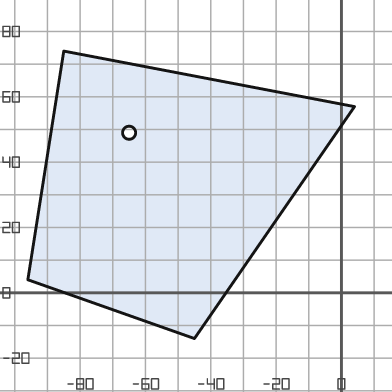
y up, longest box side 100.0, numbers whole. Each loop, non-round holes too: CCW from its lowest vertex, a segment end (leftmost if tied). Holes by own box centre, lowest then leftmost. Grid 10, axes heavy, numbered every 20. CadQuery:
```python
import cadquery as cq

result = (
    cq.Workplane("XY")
    .moveTo(-45.0, -14.0)
    .lineTo(4.0, 57.0)
    .lineTo(-85.0, 74.0)
    .lineTo(-96.0, 4.0)
    .close()
    .moveTo(-65.0, 49.0)
    .circle(2.0)
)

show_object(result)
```